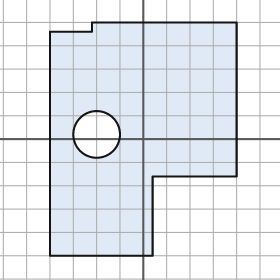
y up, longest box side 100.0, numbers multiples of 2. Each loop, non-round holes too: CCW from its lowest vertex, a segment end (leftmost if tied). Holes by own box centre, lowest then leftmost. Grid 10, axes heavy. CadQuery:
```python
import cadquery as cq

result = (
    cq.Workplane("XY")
    .moveTo(-40.0, -50.0)
    .lineTo(4.0, -50.0)
    .lineTo(4.0, -16.0)
    .lineTo(40.0, -16.0)
    .lineTo(40.0, 50.0)
    .lineTo(-22.0, 50.0)
    .lineTo(-22.0, 46.0)
    .lineTo(-40.0, 46.0)
    .close()
    .moveTo(-20.0, 2.0)
    .circle(10.0)
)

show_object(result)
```